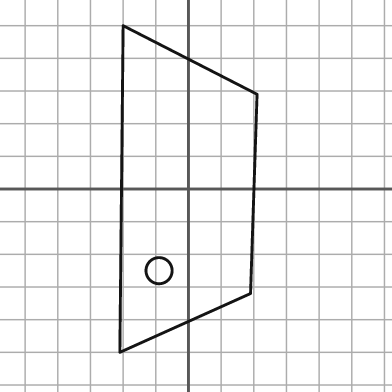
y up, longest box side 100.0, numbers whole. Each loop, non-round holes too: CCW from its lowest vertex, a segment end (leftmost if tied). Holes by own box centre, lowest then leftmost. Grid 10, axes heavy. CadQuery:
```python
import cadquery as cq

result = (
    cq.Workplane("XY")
    .moveTo(-21.0, -50.0)
    .lineTo(19.0, -32.0)
    .lineTo(21.0, 29.0)
    .lineTo(-20.0, 50.0)
    .close()
    .moveTo(-9.0, -25.0)
    .circle(4.0)
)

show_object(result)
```